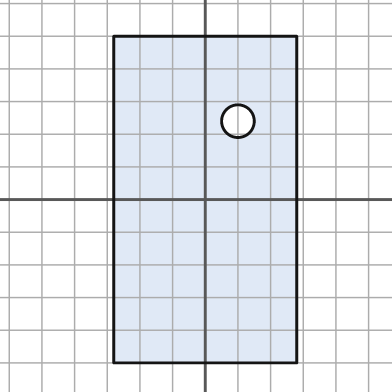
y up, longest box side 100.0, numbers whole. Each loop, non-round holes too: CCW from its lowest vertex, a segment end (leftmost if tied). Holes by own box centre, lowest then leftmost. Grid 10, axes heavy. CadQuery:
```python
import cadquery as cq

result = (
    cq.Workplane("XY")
    .moveTo(-28.0, -50.0)
    .lineTo(28.0, -50.0)
    .lineTo(28.0, 50.0)
    .lineTo(-28.0, 50.0)
    .close()
    .moveTo(10.0, 24.0)
    .circle(5.0)
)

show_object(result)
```